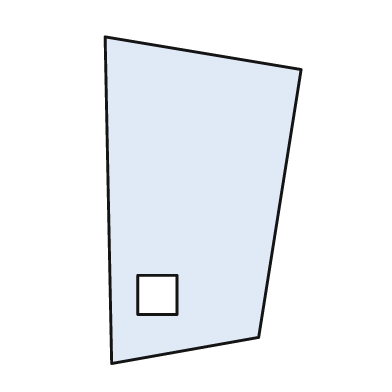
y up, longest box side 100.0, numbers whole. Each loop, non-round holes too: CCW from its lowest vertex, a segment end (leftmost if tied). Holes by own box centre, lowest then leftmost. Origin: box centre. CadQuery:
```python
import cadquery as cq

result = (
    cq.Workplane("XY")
    .moveTo(-28.0, -50.0)
    .lineTo(17.0, -42.0)
    .lineTo(30.0, 40.0)
    .lineTo(-30.0, 50.0)
    .close()
    .moveTo(-20.0, -35.0)
    .lineTo(-8.0, -35.0)
    .lineTo(-8.0, -23.0)
    .lineTo(-20.0, -23.0)
    .close()
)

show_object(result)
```